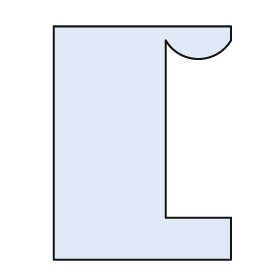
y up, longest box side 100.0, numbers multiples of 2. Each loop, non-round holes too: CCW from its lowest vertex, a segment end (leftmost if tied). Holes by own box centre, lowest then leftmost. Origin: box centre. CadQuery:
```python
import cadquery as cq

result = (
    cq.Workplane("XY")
    .moveTo(-38.0, -50.0)
    .lineTo(38.0, -50.0)
    .lineTo(38.0, -32.0)
    .lineTo(10.0, -32.0)
    .lineTo(10.0, 44.0)
    .threePointArc((24.0, 36.0), (38.0, 44.0))
    .lineTo(38.0, 50.0)
    .lineTo(-38.0, 50.0)
    .close()
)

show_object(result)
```